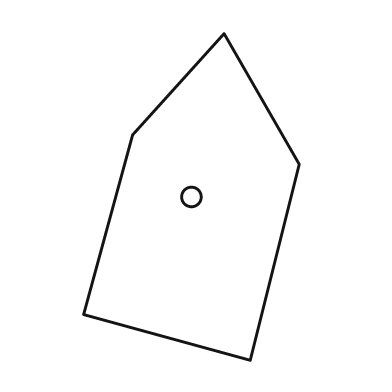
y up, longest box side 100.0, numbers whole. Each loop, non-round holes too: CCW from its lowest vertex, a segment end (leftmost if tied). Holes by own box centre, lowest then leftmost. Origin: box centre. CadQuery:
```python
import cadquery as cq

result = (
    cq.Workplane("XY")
    .moveTo(18.0, -50.0)
    .lineTo(33.0, 10.0)
    .lineTo(10.0, 50.0)
    .lineTo(-18.0, 19.0)
    .lineTo(-33.0, -36.0)
    .close()
    .moveTo(0.0, 0.0)
    .circle(3.0)
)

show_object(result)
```